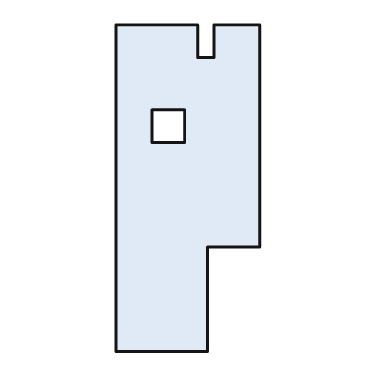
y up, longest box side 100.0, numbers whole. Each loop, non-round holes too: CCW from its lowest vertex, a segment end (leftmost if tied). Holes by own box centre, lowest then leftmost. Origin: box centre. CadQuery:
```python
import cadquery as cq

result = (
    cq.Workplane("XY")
    .moveTo(-22.0, -50.0)
    .lineTo(6.0, -50.0)
    .lineTo(6.0, -18.0)
    .lineTo(22.0, -18.0)
    .lineTo(22.0, 50.0)
    .lineTo(8.0, 50.0)
    .lineTo(8.0, 40.0)
    .lineTo(3.0, 40.0)
    .lineTo(3.0, 50.0)
    .lineTo(-22.0, 50.0)
    .close()
    .moveTo(-11.0, 14.0)
    .lineTo(-1.0, 14.0)
    .lineTo(-1.0, 24.0)
    .lineTo(-11.0, 24.0)
    .close()
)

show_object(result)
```